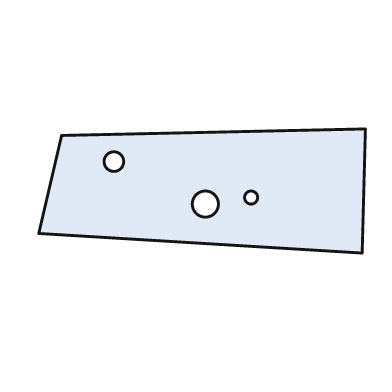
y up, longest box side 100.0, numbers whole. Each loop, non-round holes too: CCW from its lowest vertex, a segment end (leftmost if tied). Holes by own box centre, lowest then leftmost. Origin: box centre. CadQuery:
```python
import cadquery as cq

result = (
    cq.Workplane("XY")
    .moveTo(49.0, -19.0)
    .lineTo(50.0, 19.0)
    .lineTo(-43.0, 17.0)
    .lineTo(-50.0, -13.0)
    .close()
    .moveTo(1.0, -4.0)
    .circle(4.0)
    .moveTo(15.0, -2.0)
    .circle(2.0)
    .moveTo(-27.0, 9.0)
    .circle(3.0)
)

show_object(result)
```